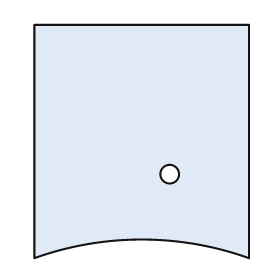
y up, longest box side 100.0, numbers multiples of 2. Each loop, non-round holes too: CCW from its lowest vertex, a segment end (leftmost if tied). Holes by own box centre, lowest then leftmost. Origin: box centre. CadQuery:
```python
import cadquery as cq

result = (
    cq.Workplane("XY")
    .moveTo(-46.0, -50.0)
    .threePointArc((0.0, -42.0), (46.0, -50.0))
    .lineTo(46.0, 50.0)
    .lineTo(-46.0, 50.0)
    .close()
    .moveTo(12.0, -14.0)
    .circle(4.0)
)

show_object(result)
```